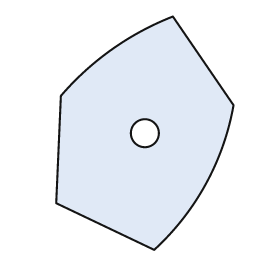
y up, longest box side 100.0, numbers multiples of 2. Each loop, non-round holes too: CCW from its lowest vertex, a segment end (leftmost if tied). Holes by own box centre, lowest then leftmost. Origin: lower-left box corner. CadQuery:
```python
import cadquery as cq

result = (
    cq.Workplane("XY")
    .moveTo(42.0, 0.0)
    .threePointArc((64.0, 28.0), (76.0, 62.0))
    .lineTo(50.0, 100.0)
    .threePointArc((24.0, 86.0), (2.0, 66.0))
    .lineTo(0.0, 20.0)
    .close()
    .moveTo(38.0, 50.0)
    .circle(6.0)
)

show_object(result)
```